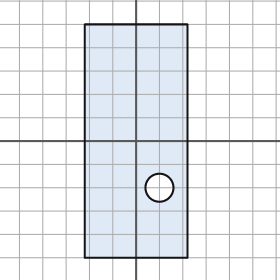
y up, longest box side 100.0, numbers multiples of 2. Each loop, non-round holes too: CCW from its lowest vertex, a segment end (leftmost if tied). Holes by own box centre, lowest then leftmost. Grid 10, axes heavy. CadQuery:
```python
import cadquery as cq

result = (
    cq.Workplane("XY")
    .moveTo(-22.0, -50.0)
    .lineTo(22.0, -50.0)
    .lineTo(22.0, 50.0)
    .lineTo(-22.0, 50.0)
    .close()
    .moveTo(10.0, -20.0)
    .circle(6.0)
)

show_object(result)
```